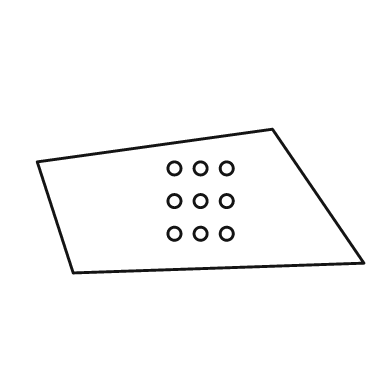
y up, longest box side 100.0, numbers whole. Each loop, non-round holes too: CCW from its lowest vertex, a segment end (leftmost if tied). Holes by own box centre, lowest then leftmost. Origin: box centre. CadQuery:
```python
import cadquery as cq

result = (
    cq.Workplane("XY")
    .moveTo(-39.0, -22.0)
    .lineTo(50.0, -19.0)
    .lineTo(22.0, 22.0)
    .lineTo(-50.0, 12.0)
    .close()
    .moveTo(-8.0, -10.0)
    .circle(2.0)
    .moveTo(0.0, -10.0)
    .circle(2.0)
    .moveTo(8.0, -10.0)
    .circle(2.0)
    .moveTo(-8.0, 0.0)
    .circle(2.0)
    .moveTo(0.0, 0.0)
    .circle(2.0)
    .moveTo(8.0, 0.0)
    .circle(2.0)
    .moveTo(-8.0, 10.0)
    .circle(2.0)
    .moveTo(0.0, 10.0)
    .circle(2.0)
    .moveTo(8.0, 10.0)
    .circle(2.0)
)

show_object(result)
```